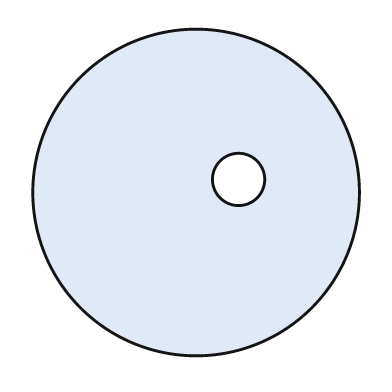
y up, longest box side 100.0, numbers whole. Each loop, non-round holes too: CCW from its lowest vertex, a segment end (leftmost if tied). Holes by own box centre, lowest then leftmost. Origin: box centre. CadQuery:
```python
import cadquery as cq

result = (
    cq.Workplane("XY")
    .moveTo(0.0, 0.0)
    .circle(50.0)
    .moveTo(13.0, 4.0)
    .circle(8.0)
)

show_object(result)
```